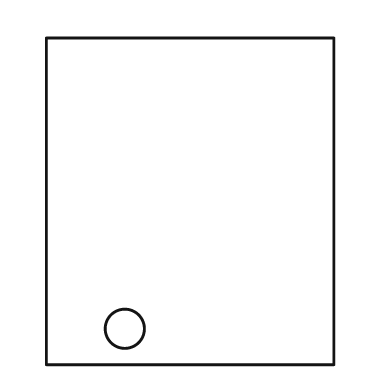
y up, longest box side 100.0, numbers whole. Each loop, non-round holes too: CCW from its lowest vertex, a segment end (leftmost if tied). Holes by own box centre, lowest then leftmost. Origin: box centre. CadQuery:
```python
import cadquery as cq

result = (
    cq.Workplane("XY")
    .moveTo(-44.0, -50.0)
    .lineTo(44.0, -50.0)
    .lineTo(44.0, 50.0)
    .lineTo(-44.0, 50.0)
    .close()
    .moveTo(-20.0, -39.0)
    .circle(6.0)
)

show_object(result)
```